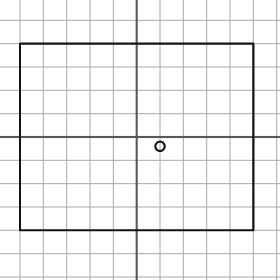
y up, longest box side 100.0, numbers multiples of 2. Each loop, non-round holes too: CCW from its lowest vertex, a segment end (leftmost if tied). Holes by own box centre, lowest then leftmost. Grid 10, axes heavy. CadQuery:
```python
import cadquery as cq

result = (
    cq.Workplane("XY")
    .moveTo(-50.0, -40.0)
    .lineTo(50.0, -40.0)
    .lineTo(50.0, 40.0)
    .lineTo(-50.0, 40.0)
    .close()
    .moveTo(10.0, -4.0)
    .circle(2.0)
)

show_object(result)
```